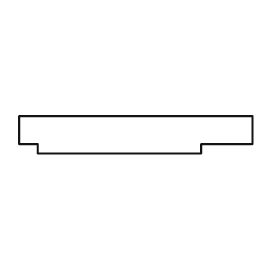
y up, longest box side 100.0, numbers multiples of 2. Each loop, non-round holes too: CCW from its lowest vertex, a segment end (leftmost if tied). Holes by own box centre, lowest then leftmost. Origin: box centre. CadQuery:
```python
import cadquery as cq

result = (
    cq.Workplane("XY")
    .moveTo(-42.0, -8.0)
    .lineTo(28.0, -8.0)
    .lineTo(28.0, -4.0)
    .lineTo(50.0, -4.0)
    .lineTo(50.0, 8.0)
    .lineTo(-50.0, 8.0)
    .lineTo(-50.0, -4.0)
    .lineTo(-42.0, -4.0)
    .close()
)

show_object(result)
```